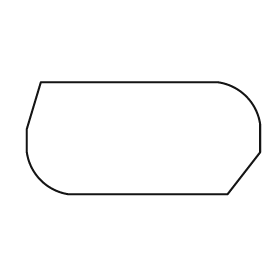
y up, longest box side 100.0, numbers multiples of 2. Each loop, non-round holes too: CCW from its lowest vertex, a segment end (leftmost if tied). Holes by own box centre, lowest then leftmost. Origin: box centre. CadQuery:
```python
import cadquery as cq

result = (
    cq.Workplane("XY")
    .moveTo(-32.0, -24.0)
    .lineTo(36.0, -24.0)
    .lineTo(50.0, -6.0)
    .lineTo(50.0, 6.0)
    .threePointArc((44.0, 18.0), (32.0, 24.0))
    .lineTo(-44.0, 24.0)
    .lineTo(-50.0, 4.0)
    .lineTo(-50.0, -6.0)
    .threePointArc((-44.0, -18.0), (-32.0, -24.0))
    .close()
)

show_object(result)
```